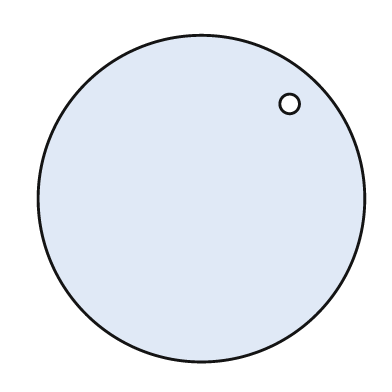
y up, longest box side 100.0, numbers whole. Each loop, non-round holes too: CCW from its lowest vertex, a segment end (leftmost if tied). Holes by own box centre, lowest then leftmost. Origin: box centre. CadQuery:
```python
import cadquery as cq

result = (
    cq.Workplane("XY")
    .moveTo(0.0, 0.0)
    .circle(50.0)
    .moveTo(27.0, 29.0)
    .circle(3.0)
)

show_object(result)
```